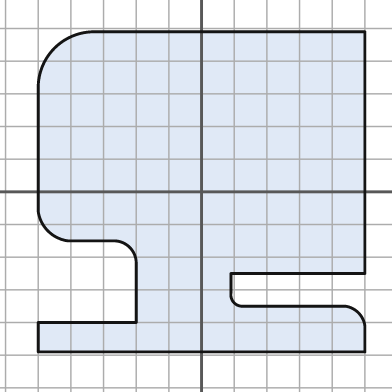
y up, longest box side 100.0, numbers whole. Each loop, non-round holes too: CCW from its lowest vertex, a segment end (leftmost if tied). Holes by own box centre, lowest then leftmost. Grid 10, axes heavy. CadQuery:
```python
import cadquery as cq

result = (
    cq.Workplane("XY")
    .moveTo(-50.0, -49.0)
    .lineTo(50.0, -49.0)
    .lineTo(50.0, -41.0)
    .threePointArc((48.0, -37.0), (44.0, -35.0))
    .lineTo(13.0, -35.0)
    .threePointArc((10.0, -34.0), (9.0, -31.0))
    .lineTo(9.0, -25.0)
    .lineTo(50.0, -25.0)
    .lineTo(50.0, 49.0)
    .lineTo(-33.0, 49.0)
    .threePointArc((-45.0, 44.0), (-50.0, 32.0))
    .lineTo(-50.0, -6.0)
    .threePointArc((-47.0, -12.0), (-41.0, -15.0))
    .lineTo(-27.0, -15.0)
    .threePointArc((-22.0, -17.0), (-20.0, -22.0))
    .lineTo(-20.0, -40.0)
    .lineTo(-50.0, -40.0)
    .close()
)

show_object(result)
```